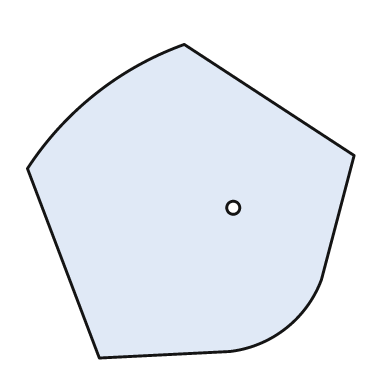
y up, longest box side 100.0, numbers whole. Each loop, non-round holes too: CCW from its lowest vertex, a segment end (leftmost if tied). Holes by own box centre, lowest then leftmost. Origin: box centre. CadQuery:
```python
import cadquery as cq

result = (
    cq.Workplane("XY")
    .moveTo(-28.0, -48.0)
    .lineTo(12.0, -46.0)
    .threePointArc((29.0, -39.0), (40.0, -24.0))
    .lineTo(50.0, 14.0)
    .lineTo(-2.0, 48.0)
    .threePointArc((-29.0, 33.0), (-50.0, 10.0))
    .close()
    .moveTo(13.0, -2.0)
    .circle(2.0)
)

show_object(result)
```